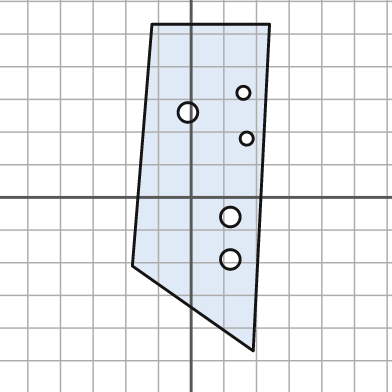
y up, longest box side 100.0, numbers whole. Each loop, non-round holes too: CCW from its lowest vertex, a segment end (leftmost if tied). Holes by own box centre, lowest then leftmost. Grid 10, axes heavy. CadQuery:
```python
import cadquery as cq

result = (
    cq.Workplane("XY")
    .moveTo(19.0, -47.0)
    .lineTo(24.0, 53.0)
    .lineTo(-12.0, 53.0)
    .lineTo(-18.0, -21.0)
    .close()
    .moveTo(12.0, -19.0)
    .circle(3.0)
    .moveTo(12.0, -6.0)
    .circle(3.0)
    .moveTo(17.0, 18.0)
    .circle(2.0)
    .moveTo(-1.0, 26.0)
    .circle(3.0)
    .moveTo(16.0, 32.0)
    .circle(2.0)
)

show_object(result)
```